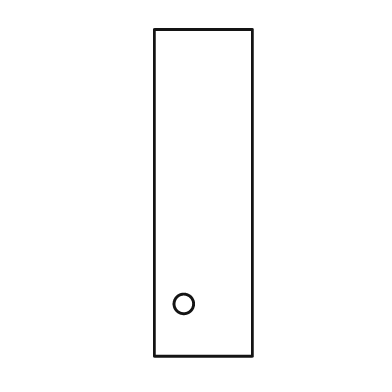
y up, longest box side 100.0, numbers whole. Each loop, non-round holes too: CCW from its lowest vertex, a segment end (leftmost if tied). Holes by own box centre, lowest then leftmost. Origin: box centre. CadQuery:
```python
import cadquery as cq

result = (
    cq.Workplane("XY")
    .moveTo(-15.0, -50.0)
    .lineTo(15.0, -50.0)
    .lineTo(15.0, 50.0)
    .lineTo(-15.0, 50.0)
    .close()
    .moveTo(-6.0, -34.0)
    .circle(3.0)
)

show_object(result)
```